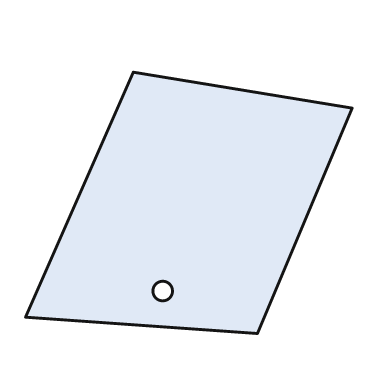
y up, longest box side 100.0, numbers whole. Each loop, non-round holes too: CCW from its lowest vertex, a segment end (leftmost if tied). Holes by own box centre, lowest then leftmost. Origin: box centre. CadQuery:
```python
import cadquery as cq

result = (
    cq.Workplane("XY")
    .moveTo(21.0, -40.0)
    .lineTo(50.0, 29.0)
    .lineTo(-17.0, 40.0)
    .lineTo(-50.0, -35.0)
    .close()
    .moveTo(-8.0, -27.0)
    .circle(3.0)
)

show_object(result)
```